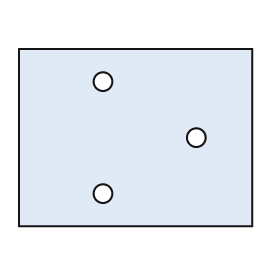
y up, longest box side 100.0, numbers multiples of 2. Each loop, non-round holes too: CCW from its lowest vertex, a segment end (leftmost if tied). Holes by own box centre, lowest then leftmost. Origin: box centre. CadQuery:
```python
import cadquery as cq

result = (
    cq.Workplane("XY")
    .moveTo(-50.0, -38.0)
    .lineTo(50.0, -38.0)
    .lineTo(50.0, 38.0)
    .lineTo(-50.0, 38.0)
    .close()
    .moveTo(-14.0, -24.0)
    .circle(4.0)
    .moveTo(26.0, 0.0)
    .circle(4.0)
    .moveTo(-14.0, 24.0)
    .circle(4.0)
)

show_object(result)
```